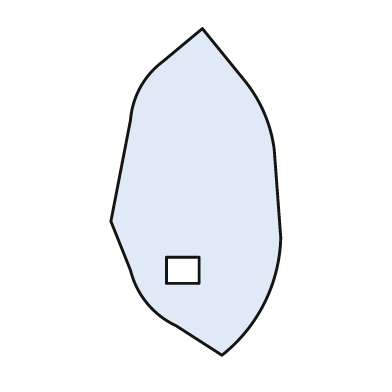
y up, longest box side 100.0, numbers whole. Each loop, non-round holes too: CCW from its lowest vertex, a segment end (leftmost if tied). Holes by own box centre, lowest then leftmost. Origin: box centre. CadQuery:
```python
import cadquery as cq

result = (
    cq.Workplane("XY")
    .moveTo(8.0, -50.0)
    .threePointArc((21.0, -34.0), (26.0, -14.0))
    .lineTo(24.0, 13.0)
    .threePointArc((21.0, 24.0), (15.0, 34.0))
    .lineTo(2.0, 50.0)
    .lineTo(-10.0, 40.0)
    .threePointArc((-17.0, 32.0), (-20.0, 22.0))
    .lineTo(-26.0, -9.0)
    .lineTo(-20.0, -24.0)
    .threePointArc((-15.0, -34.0), (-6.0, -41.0))
    .close()
    .moveTo(-9.0, -28.0)
    .lineTo(1.0, -28.0)
    .lineTo(1.0, -20.0)
    .lineTo(-9.0, -20.0)
    .close()
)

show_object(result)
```